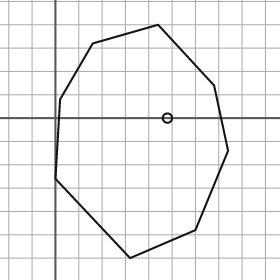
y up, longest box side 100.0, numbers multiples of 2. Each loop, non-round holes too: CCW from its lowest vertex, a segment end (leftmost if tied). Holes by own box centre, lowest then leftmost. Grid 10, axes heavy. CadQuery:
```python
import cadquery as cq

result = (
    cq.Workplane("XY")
    .moveTo(32.0, -60.0)
    .lineTo(60.0, -48.0)
    .lineTo(74.0, -14.0)
    .lineTo(68.0, 14.0)
    .lineTo(44.0, 40.0)
    .lineTo(16.0, 32.0)
    .lineTo(2.0, 8.0)
    .lineTo(0.0, -26.0)
    .close()
    .moveTo(48.0, 0.0)
    .circle(2.0)
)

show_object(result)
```